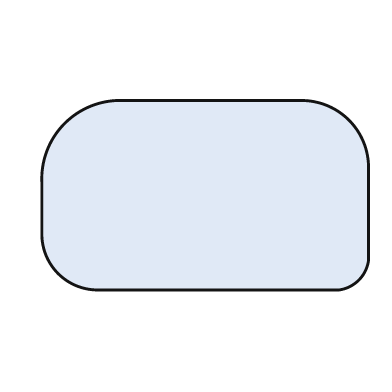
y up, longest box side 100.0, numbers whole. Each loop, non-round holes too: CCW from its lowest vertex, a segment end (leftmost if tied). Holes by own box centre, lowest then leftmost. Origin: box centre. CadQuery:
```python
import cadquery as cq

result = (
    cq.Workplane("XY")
    .moveTo(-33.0, -29.0)
    .lineTo(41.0, -29.0)
    .threePointArc((47.0, -26.0), (50.0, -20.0))
    .lineTo(50.0, 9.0)
    .threePointArc((44.0, 23.0), (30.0, 29.0))
    .lineTo(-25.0, 29.0)
    .threePointArc((-43.0, 22.0), (-50.0, 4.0))
    .lineTo(-50.0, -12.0)
    .threePointArc((-45.0, -24.0), (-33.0, -29.0))
    .close()
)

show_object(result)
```